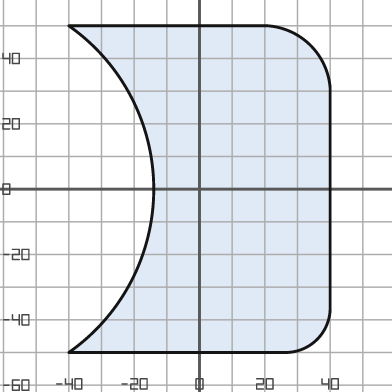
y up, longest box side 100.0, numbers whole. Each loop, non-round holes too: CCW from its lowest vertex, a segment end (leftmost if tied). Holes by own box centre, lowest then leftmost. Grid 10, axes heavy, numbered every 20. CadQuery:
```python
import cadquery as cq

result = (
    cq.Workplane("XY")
    .moveTo(-40.0, -50.0)
    .lineTo(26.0, -50.0)
    .threePointArc((36.0, -46.0), (40.0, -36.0))
    .lineTo(40.0, 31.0)
    .threePointArc((34.0, 44.0), (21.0, 50.0))
    .lineTo(-40.0, 50.0)
    .threePointArc((-14.0, 0.0), (-40.0, -50.0))
    .close()
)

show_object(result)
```